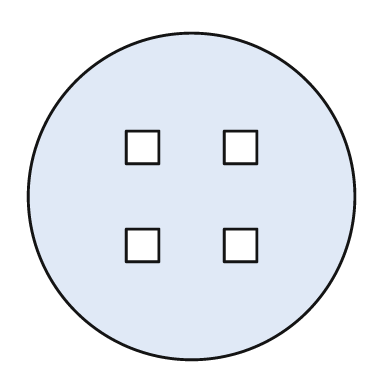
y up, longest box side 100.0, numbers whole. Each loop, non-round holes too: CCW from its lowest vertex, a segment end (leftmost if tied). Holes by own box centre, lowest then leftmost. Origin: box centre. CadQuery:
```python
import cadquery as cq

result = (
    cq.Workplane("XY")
    .moveTo(0.0, 0.0)
    .circle(50.0)
    .moveTo(-20.0, -20.0)
    .lineTo(-10.0, -20.0)
    .lineTo(-10.0, -10.0)
    .lineTo(-20.0, -10.0)
    .close()
    .moveTo(10.0, -20.0)
    .lineTo(20.0, -20.0)
    .lineTo(20.0, -10.0)
    .lineTo(10.0, -10.0)
    .close()
    .moveTo(-20.0, 10.0)
    .lineTo(-10.0, 10.0)
    .lineTo(-10.0, 20.0)
    .lineTo(-20.0, 20.0)
    .close()
    .moveTo(10.0, 10.0)
    .lineTo(20.0, 10.0)
    .lineTo(20.0, 20.0)
    .lineTo(10.0, 20.0)
    .close()
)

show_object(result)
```